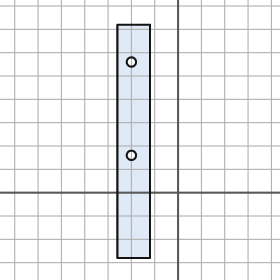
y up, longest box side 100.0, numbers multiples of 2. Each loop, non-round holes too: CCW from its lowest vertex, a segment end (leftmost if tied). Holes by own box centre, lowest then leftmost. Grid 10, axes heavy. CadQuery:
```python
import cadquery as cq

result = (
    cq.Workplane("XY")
    .moveTo(-26.0, -28.0)
    .lineTo(-12.0, -28.0)
    .lineTo(-12.0, 72.0)
    .lineTo(-26.0, 72.0)
    .close()
    .moveTo(-20.0, 16.0)
    .circle(2.0)
    .moveTo(-20.0, 56.0)
    .circle(2.0)
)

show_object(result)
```